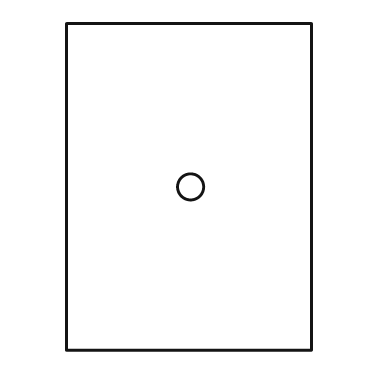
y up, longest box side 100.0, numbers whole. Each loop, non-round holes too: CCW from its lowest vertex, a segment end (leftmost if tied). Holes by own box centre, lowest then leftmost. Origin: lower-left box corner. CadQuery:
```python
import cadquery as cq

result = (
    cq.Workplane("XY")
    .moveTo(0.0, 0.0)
    .lineTo(75.0, 0.0)
    .lineTo(75.0, 100.0)
    .lineTo(0.0, 100.0)
    .close()
    .moveTo(38.0, 50.0)
    .circle(4.0)
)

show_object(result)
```